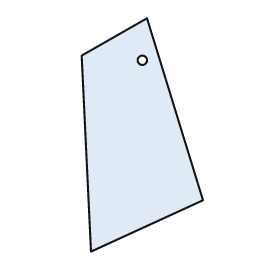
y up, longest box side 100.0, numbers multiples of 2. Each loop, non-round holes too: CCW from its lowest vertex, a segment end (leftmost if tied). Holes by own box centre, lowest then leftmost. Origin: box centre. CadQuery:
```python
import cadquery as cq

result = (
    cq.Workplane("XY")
    .moveTo(-22.0, -50.0)
    .lineTo(26.0, -28.0)
    .lineTo(2.0, 50.0)
    .lineTo(-26.0, 34.0)
    .close()
    .moveTo(0.0, 32.0)
    .circle(2.0)
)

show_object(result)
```